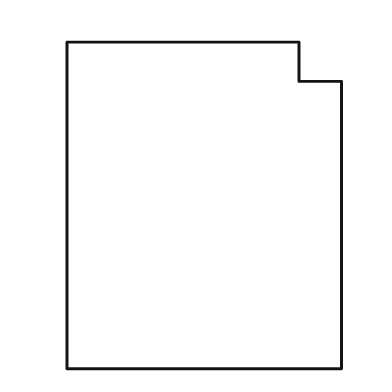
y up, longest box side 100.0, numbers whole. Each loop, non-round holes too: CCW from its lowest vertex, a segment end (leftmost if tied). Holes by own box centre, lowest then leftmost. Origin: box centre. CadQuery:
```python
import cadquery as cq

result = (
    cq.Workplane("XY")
    .moveTo(-42.0, -50.0)
    .lineTo(42.0, -50.0)
    .lineTo(42.0, 38.0)
    .lineTo(29.0, 38.0)
    .lineTo(29.0, 50.0)
    .lineTo(-42.0, 50.0)
    .close()
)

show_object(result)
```